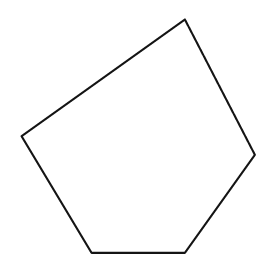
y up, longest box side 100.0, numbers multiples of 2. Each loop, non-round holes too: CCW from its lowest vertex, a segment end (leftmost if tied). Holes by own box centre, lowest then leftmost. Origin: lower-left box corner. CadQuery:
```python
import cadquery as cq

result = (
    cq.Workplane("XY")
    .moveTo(30.0, 0.0)
    .lineTo(70.0, 0.0)
    .lineTo(100.0, 42.0)
    .lineTo(70.0, 100.0)
    .lineTo(0.0, 50.0)
    .close()
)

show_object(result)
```